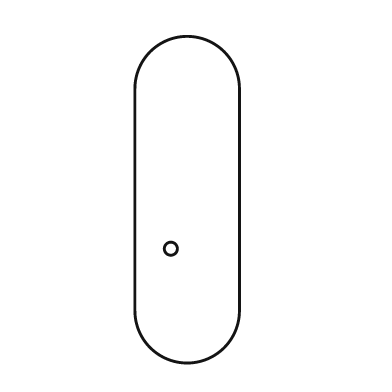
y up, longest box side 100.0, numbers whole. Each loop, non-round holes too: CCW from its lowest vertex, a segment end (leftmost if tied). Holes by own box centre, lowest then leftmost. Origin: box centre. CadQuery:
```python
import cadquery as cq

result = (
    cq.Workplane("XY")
    .moveTo(-16.0, -34.0)
    .threePointArc((0.0, -50.0), (16.0, -34.0))
    .lineTo(16.0, 34.0)
    .threePointArc((0.0, 50.0), (-16.0, 34.0))
    .close()
    .moveTo(-5.0, -15.0)
    .circle(2.0)
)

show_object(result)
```